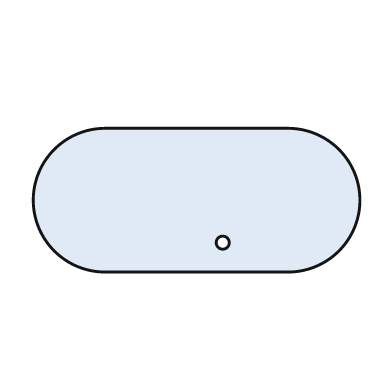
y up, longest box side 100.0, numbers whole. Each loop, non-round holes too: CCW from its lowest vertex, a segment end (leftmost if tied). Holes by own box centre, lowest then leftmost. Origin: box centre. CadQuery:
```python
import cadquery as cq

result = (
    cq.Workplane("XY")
    .moveTo(-28.0, -22.0)
    .lineTo(28.0, -22.0)
    .threePointArc((50.0, 0.0), (28.0, 22.0))
    .lineTo(-28.0, 22.0)
    .threePointArc((-50.0, 0.0), (-28.0, -22.0))
    .close()
    .moveTo(8.0, -13.0)
    .circle(2.0)
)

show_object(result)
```